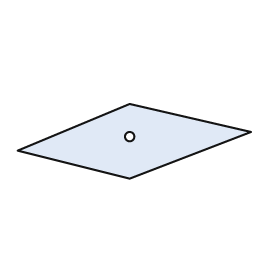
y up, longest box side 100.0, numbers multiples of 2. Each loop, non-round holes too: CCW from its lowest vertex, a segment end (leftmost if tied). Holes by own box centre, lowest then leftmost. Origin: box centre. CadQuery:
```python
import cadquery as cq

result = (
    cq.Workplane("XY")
    .moveTo(-2.0, -16.0)
    .lineTo(50.0, 4.0)
    .lineTo(-2.0, 16.0)
    .lineTo(-50.0, -4.0)
    .close()
    .moveTo(-2.0, 2.0)
    .circle(2.0)
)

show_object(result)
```